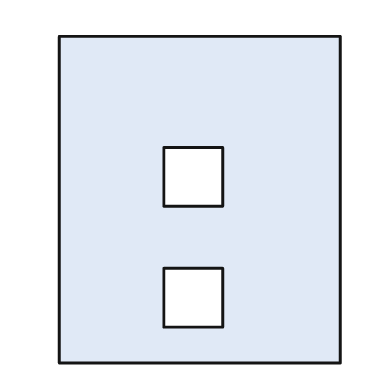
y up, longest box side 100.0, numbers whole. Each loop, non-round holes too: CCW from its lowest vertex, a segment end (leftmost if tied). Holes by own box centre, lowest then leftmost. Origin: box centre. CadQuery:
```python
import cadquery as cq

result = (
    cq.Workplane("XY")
    .moveTo(-43.0, -50.0)
    .lineTo(43.0, -50.0)
    .lineTo(43.0, 50.0)
    .lineTo(-43.0, 50.0)
    .close()
    .moveTo(-11.0, -39.0)
    .lineTo(7.0, -39.0)
    .lineTo(7.0, -21.0)
    .lineTo(-11.0, -21.0)
    .close()
    .moveTo(-11.0, -2.0)
    .lineTo(7.0, -2.0)
    .lineTo(7.0, 16.0)
    .lineTo(-11.0, 16.0)
    .close()
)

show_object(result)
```